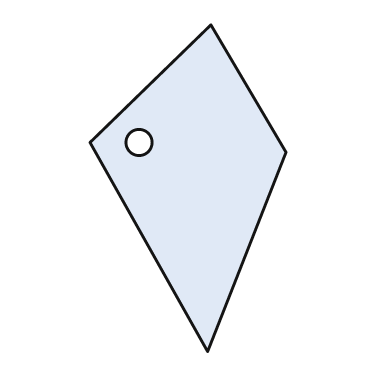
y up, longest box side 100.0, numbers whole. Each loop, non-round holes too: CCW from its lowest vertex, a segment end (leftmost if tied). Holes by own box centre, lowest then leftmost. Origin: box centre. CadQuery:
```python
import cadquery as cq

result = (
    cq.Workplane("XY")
    .moveTo(6.0, -50.0)
    .lineTo(30.0, 11.0)
    .lineTo(7.0, 50.0)
    .lineTo(-30.0, 14.0)
    .close()
    .moveTo(-15.0, 14.0)
    .circle(4.0)
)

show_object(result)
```